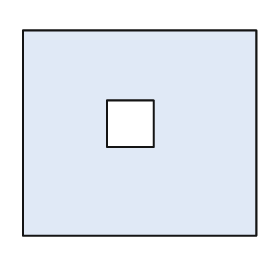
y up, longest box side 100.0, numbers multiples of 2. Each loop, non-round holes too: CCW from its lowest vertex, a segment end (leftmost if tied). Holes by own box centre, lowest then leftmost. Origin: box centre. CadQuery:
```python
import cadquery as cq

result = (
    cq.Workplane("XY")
    .moveTo(-50.0, -44.0)
    .lineTo(50.0, -44.0)
    .lineTo(50.0, 44.0)
    .lineTo(-50.0, 44.0)
    .close()
    .moveTo(-14.0, -6.0)
    .lineTo(6.0, -6.0)
    .lineTo(6.0, 14.0)
    .lineTo(-14.0, 14.0)
    .close()
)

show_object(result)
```